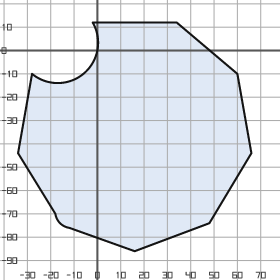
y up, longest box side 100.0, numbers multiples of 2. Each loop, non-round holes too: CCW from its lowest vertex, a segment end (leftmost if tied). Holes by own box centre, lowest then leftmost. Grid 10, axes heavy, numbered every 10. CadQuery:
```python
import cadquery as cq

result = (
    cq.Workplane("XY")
    .moveTo(16.0, -86.0)
    .lineTo(48.0, -74.0)
    .lineTo(66.0, -44.0)
    .lineTo(60.0, -10.0)
    .lineTo(34.0, 12.0)
    .lineTo(-2.0, 12.0)
    .threePointArc((-6.0, -10.0), (-28.0, -10.0))
    .lineTo(-34.0, -44.0)
    .lineTo(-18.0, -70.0)
    .threePointArc((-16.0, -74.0), (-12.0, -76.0))
    .close()
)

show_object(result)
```